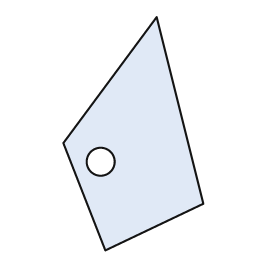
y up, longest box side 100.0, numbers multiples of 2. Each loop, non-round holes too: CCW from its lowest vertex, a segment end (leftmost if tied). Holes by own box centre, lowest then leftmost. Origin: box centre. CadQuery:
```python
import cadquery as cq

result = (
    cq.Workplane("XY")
    .moveTo(-12.0, -50.0)
    .lineTo(30.0, -30.0)
    .lineTo(10.0, 50.0)
    .lineTo(-30.0, -4.0)
    .close()
    .moveTo(-14.0, -12.0)
    .circle(6.0)
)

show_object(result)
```